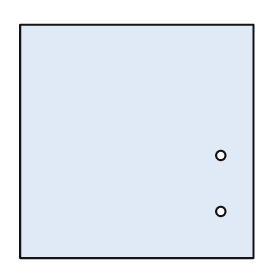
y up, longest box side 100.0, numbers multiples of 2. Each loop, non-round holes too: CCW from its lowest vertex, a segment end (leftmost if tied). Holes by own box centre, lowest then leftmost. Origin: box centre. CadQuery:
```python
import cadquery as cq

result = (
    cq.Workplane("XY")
    .moveTo(-50.0, -50.0)
    .lineTo(50.0, -50.0)
    .lineTo(50.0, 50.0)
    .lineTo(-50.0, 50.0)
    .close()
    .moveTo(36.0, -30.0)
    .circle(2.0)
    .moveTo(36.0, -6.0)
    .circle(2.0)
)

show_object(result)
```